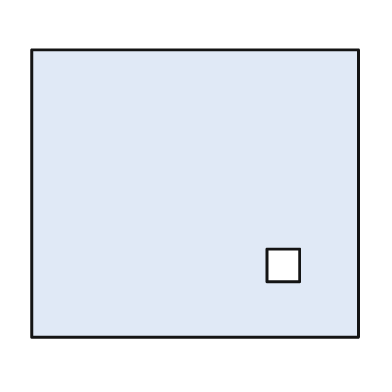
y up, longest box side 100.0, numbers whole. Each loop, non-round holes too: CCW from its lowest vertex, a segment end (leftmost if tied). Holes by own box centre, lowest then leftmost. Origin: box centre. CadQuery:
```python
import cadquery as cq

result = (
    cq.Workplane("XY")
    .moveTo(-50.0, -44.0)
    .lineTo(50.0, -44.0)
    .lineTo(50.0, 44.0)
    .lineTo(-50.0, 44.0)
    .close()
    .moveTo(22.0, -27.0)
    .lineTo(32.0, -27.0)
    .lineTo(32.0, -17.0)
    .lineTo(22.0, -17.0)
    .close()
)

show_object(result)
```